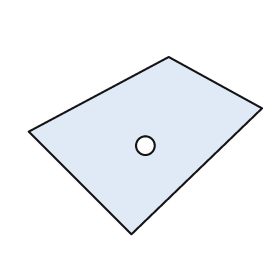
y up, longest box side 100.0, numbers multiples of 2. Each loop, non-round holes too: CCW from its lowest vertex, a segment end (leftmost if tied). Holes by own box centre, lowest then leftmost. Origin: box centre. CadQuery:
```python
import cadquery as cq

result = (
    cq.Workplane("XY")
    .moveTo(-6.0, -38.0)
    .lineTo(50.0, 16.0)
    .lineTo(10.0, 38.0)
    .lineTo(-50.0, 6.0)
    .close()
    .moveTo(0.0, 0.0)
    .circle(4.0)
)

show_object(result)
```